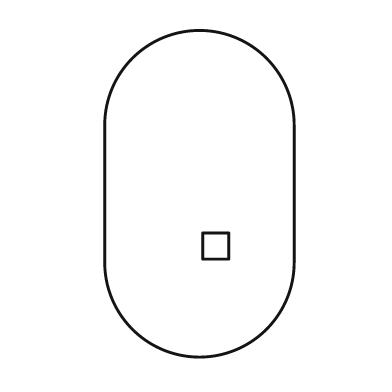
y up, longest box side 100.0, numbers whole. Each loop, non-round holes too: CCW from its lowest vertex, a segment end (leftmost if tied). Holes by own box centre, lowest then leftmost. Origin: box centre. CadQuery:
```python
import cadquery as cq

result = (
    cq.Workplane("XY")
    .moveTo(-29.0, -21.0)
    .threePointArc((0.0, -50.0), (29.0, -21.0))
    .lineTo(29.0, 21.0)
    .threePointArc((0.0, 50.0), (-29.0, 21.0))
    .close()
    .moveTo(1.0, -20.0)
    .lineTo(9.0, -20.0)
    .lineTo(9.0, -12.0)
    .lineTo(1.0, -12.0)
    .close()
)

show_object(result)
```